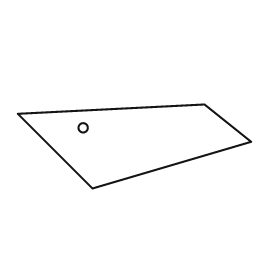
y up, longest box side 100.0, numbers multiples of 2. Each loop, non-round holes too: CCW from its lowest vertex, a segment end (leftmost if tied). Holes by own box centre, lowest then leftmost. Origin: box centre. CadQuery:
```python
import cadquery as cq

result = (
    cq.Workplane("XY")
    .moveTo(-18.0, -18.0)
    .lineTo(50.0, 2.0)
    .lineTo(30.0, 18.0)
    .lineTo(-50.0, 14.0)
    .close()
    .moveTo(-22.0, 8.0)
    .circle(2.0)
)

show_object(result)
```